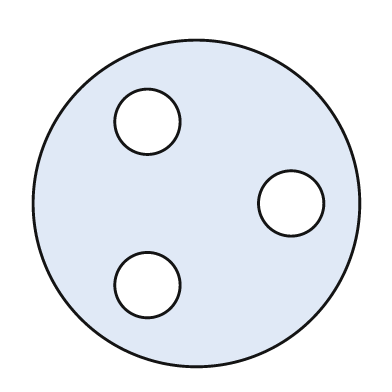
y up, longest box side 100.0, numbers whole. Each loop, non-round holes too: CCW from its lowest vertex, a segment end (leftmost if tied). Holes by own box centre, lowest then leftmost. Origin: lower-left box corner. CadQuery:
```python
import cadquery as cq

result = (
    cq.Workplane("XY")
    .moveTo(50.0, 50.0)
    .circle(50.0)
    .moveTo(35.0, 25.0)
    .circle(10.0)
    .moveTo(79.0, 50.0)
    .circle(10.0)
    .moveTo(35.0, 75.0)
    .circle(10.0)
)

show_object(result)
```